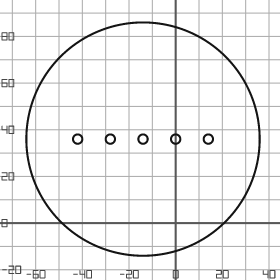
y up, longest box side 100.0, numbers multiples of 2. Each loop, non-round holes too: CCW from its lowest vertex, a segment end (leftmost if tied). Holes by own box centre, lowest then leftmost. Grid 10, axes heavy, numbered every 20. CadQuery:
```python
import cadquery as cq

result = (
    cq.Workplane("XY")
    .moveTo(-14.0, 36.0)
    .circle(50.0)
    .moveTo(-42.0, 36.0)
    .circle(2.0)
    .moveTo(-28.0, 36.0)
    .circle(2.0)
    .moveTo(-14.0, 36.0)
    .circle(2.0)
    .moveTo(0.0, 36.0)
    .circle(2.0)
    .moveTo(14.0, 36.0)
    .circle(2.0)
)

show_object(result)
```